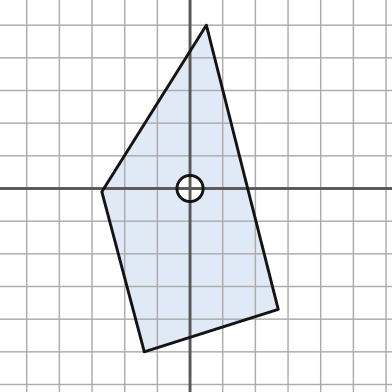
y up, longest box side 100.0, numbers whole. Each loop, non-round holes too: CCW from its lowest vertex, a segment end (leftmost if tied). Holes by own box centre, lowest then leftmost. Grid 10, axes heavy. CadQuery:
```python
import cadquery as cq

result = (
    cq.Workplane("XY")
    .moveTo(-14.0, -50.0)
    .lineTo(27.0, -37.0)
    .lineTo(5.0, 50.0)
    .lineTo(-27.0, -1.0)
    .close()
    .moveTo(0.0, 0.0)
    .circle(4.0)
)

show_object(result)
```